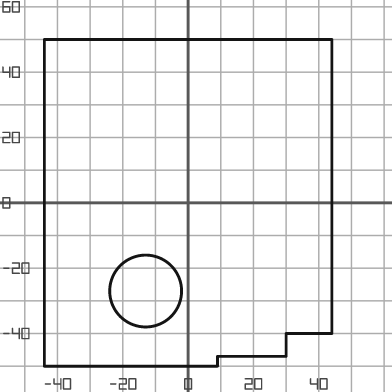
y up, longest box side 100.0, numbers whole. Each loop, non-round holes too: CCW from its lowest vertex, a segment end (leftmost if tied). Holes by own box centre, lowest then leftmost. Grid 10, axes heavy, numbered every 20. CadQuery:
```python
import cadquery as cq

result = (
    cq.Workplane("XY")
    .moveTo(-44.0, -50.0)
    .lineTo(9.0, -50.0)
    .lineTo(9.0, -47.0)
    .lineTo(30.0, -47.0)
    .lineTo(30.0, -40.0)
    .lineTo(44.0, -40.0)
    .lineTo(44.0, 50.0)
    .lineTo(-44.0, 50.0)
    .close()
    .moveTo(-13.0, -27.0)
    .circle(11.0)
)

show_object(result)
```